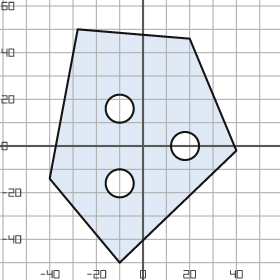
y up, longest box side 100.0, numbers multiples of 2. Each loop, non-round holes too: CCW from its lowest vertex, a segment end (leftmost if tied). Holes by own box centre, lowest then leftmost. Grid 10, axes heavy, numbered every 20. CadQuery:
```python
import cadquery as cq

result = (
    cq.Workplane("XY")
    .moveTo(-10.0, -50.0)
    .lineTo(40.0, -2.0)
    .lineTo(20.0, 46.0)
    .lineTo(-28.0, 50.0)
    .lineTo(-40.0, -14.0)
    .close()
    .moveTo(-10.0, -16.0)
    .circle(6.0)
    .moveTo(18.0, 0.0)
    .circle(6.0)
    .moveTo(-10.0, 16.0)
    .circle(6.0)
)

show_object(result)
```